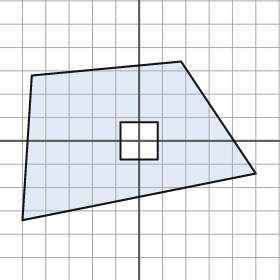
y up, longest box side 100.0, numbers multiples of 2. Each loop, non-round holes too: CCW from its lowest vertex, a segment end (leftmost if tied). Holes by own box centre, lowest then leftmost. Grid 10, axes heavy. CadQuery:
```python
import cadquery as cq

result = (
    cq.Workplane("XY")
    .moveTo(-50.0, -34.0)
    .lineTo(50.0, -14.0)
    .lineTo(18.0, 34.0)
    .lineTo(-46.0, 28.0)
    .close()
    .moveTo(-8.0, -8.0)
    .lineTo(8.0, -8.0)
    .lineTo(8.0, 8.0)
    .lineTo(-8.0, 8.0)
    .close()
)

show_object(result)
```